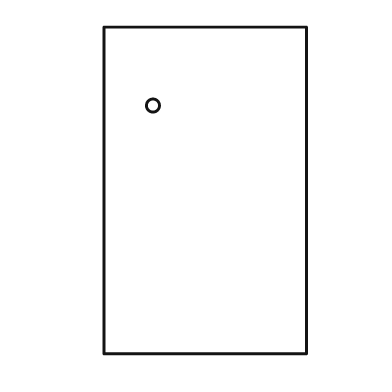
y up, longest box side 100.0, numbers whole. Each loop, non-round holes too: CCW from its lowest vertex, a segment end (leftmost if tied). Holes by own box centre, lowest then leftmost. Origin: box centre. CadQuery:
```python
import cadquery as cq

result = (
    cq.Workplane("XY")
    .moveTo(-31.0, -50.0)
    .lineTo(31.0, -50.0)
    .lineTo(31.0, 50.0)
    .lineTo(-31.0, 50.0)
    .close()
    .moveTo(-16.0, 26.0)
    .circle(2.0)
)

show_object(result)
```